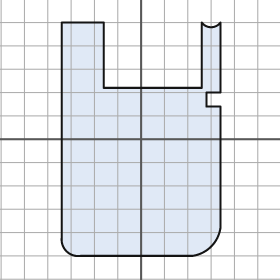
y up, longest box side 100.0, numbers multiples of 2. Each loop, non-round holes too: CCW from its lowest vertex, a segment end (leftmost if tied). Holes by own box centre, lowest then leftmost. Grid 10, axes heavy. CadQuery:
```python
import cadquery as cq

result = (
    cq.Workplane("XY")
    .moveTo(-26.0, -50.0)
    .lineTo(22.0, -50.0)
    .threePointArc((30.0, -46.0), (34.0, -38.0))
    .lineTo(34.0, 14.0)
    .lineTo(28.0, 14.0)
    .lineTo(28.0, 20.0)
    .lineTo(34.0, 20.0)
    .lineTo(34.0, 50.0)
    .threePointArc((30.0, 48.0), (26.0, 50.0))
    .lineTo(26.0, 22.0)
    .lineTo(-16.0, 22.0)
    .lineTo(-16.0, 50.0)
    .lineTo(-34.0, 50.0)
    .lineTo(-34.0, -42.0)
    .threePointArc((-32.0, -48.0), (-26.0, -50.0))
    .close()
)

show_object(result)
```